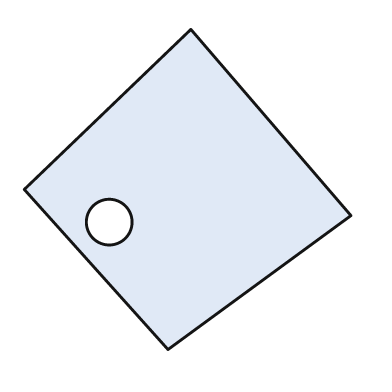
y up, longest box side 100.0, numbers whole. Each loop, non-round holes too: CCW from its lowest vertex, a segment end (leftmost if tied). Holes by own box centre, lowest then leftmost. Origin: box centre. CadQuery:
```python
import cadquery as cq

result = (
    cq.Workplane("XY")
    .moveTo(-6.0, -49.0)
    .lineTo(50.0, -8.0)
    .lineTo(1.0, 49.0)
    .lineTo(-50.0, 0.0)
    .close()
    .moveTo(-24.0, -10.0)
    .circle(7.0)
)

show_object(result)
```